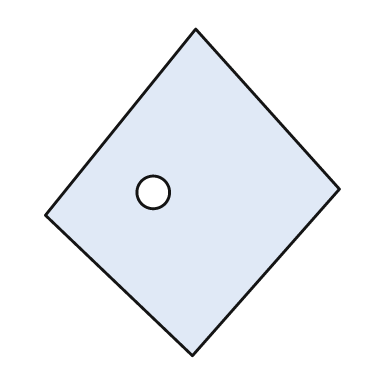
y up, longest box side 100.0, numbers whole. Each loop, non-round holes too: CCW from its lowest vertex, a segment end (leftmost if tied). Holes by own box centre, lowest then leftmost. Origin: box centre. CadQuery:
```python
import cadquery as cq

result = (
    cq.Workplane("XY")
    .moveTo(0.0, -50.0)
    .lineTo(45.0, 1.0)
    .lineTo(1.0, 50.0)
    .lineTo(-45.0, -7.0)
    .close()
    .moveTo(-12.0, 0.0)
    .circle(5.0)
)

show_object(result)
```